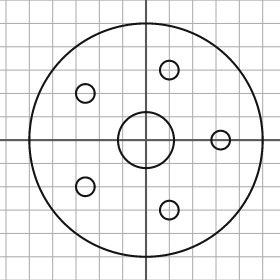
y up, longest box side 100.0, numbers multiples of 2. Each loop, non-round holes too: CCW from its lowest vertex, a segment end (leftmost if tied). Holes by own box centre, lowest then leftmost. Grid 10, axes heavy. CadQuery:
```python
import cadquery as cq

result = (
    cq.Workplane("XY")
    .moveTo(0.0, 0.0)
    .circle(50.0)
    .moveTo(10.0, -30.0)
    .circle(4.0)
    .moveTo(-26.0, -20.0)
    .circle(4.0)
    .moveTo(0.0, 0.0)
    .circle(12.0)
    .moveTo(32.0, 0.0)
    .circle(4.0)
    .moveTo(-26.0, 20.0)
    .circle(4.0)
    .moveTo(10.0, 30.0)
    .circle(4.0)
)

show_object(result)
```